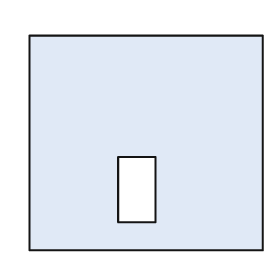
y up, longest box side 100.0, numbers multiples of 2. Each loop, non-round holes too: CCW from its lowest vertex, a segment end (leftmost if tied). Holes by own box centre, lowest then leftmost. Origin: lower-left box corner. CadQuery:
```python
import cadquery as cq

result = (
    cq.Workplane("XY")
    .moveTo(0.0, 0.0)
    .lineTo(100.0, 0.0)
    .lineTo(100.0, 92.0)
    .lineTo(0.0, 92.0)
    .close()
    .moveTo(38.0, 12.0)
    .lineTo(54.0, 12.0)
    .lineTo(54.0, 40.0)
    .lineTo(38.0, 40.0)
    .close()
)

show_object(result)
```